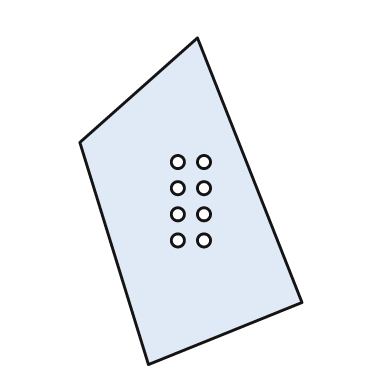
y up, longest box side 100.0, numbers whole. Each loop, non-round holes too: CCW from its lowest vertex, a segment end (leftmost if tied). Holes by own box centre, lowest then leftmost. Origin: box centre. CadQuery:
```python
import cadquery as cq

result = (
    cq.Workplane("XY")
    .moveTo(-13.0, -50.0)
    .lineTo(34.0, -31.0)
    .lineTo(2.0, 50.0)
    .lineTo(-34.0, 18.0)
    .close()
    .moveTo(-4.0, -12.0)
    .circle(2.0)
    .moveTo(4.0, -12.0)
    .circle(2.0)
    .moveTo(-4.0, -4.0)
    .circle(2.0)
    .moveTo(4.0, -4.0)
    .circle(2.0)
    .moveTo(-4.0, 4.0)
    .circle(2.0)
    .moveTo(4.0, 4.0)
    .circle(2.0)
    .moveTo(-4.0, 12.0)
    .circle(2.0)
    .moveTo(4.0, 12.0)
    .circle(2.0)
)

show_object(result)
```